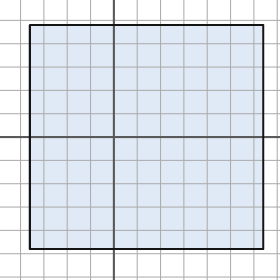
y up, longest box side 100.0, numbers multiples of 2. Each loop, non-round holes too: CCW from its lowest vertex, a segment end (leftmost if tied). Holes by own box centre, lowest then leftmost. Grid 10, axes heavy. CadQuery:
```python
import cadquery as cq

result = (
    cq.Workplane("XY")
    .moveTo(-36.0, -48.0)
    .lineTo(64.0, -48.0)
    .lineTo(64.0, 48.0)
    .lineTo(-36.0, 48.0)
    .close()
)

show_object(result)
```